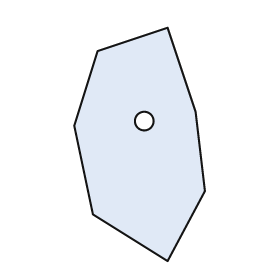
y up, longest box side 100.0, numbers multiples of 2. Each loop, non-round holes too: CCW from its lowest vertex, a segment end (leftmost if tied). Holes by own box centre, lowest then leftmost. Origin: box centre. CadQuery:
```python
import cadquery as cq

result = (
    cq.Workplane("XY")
    .moveTo(12.0, -50.0)
    .lineTo(28.0, -20.0)
    .lineTo(24.0, 14.0)
    .lineTo(12.0, 50.0)
    .lineTo(-18.0, 40.0)
    .lineTo(-28.0, 8.0)
    .lineTo(-20.0, -30.0)
    .close()
    .moveTo(2.0, 10.0)
    .circle(4.0)
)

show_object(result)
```